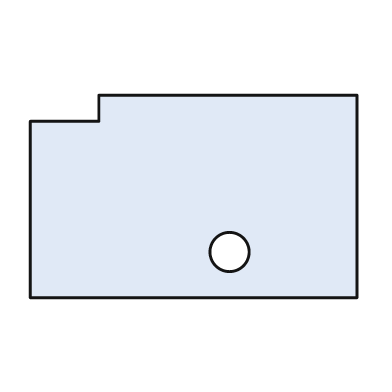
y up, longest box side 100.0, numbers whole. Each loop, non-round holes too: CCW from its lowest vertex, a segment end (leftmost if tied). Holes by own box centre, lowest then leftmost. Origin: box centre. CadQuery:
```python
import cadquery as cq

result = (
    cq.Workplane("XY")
    .moveTo(-50.0, -31.0)
    .lineTo(50.0, -31.0)
    .lineTo(50.0, 31.0)
    .lineTo(-29.0, 31.0)
    .lineTo(-29.0, 23.0)
    .lineTo(-50.0, 23.0)
    .close()
    .moveTo(11.0, -17.0)
    .circle(6.0)
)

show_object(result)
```